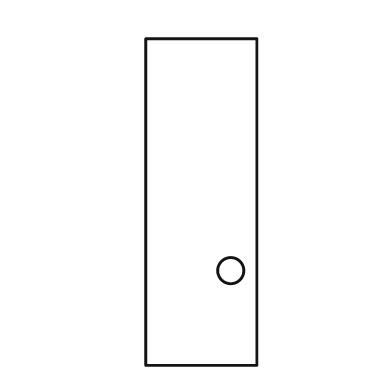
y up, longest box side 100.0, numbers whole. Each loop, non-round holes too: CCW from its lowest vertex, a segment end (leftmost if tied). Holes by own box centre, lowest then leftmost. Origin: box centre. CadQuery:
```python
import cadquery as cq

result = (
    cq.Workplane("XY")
    .moveTo(-17.0, -50.0)
    .lineTo(17.0, -50.0)
    .lineTo(17.0, 50.0)
    .lineTo(-17.0, 50.0)
    .close()
    .moveTo(9.0, -21.0)
    .circle(4.0)
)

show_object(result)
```